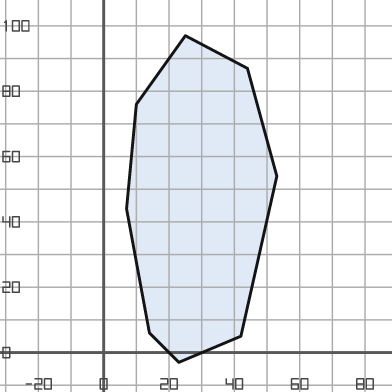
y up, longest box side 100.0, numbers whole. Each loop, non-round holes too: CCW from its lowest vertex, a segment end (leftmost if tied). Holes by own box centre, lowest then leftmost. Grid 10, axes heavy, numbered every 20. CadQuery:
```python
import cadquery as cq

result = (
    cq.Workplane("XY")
    .moveTo(23.0, -3.0)
    .lineTo(42.0, 5.0)
    .lineTo(53.0, 54.0)
    .lineTo(44.0, 87.0)
    .lineTo(25.0, 97.0)
    .lineTo(10.0, 76.0)
    .lineTo(7.0, 44.0)
    .lineTo(14.0, 6.0)
    .close()
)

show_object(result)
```